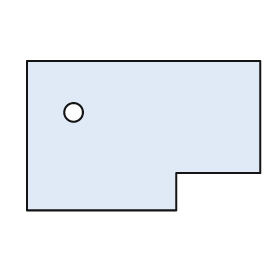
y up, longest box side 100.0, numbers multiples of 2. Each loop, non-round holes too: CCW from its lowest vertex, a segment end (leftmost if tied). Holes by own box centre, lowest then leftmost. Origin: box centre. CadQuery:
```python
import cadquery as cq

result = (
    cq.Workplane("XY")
    .moveTo(-50.0, -32.0)
    .lineTo(14.0, -32.0)
    .lineTo(14.0, -16.0)
    .lineTo(50.0, -16.0)
    .lineTo(50.0, 32.0)
    .lineTo(-50.0, 32.0)
    .close()
    .moveTo(-30.0, 10.0)
    .circle(4.0)
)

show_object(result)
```